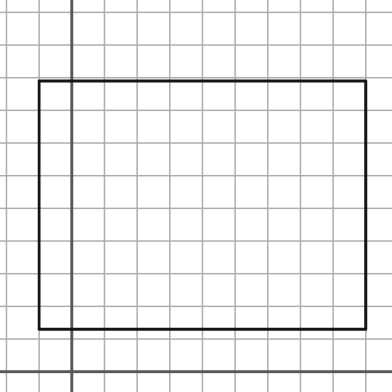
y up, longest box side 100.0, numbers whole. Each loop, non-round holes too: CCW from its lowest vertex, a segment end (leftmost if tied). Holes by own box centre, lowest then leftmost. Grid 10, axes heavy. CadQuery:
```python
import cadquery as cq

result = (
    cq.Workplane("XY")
    .moveTo(-10.0, 13.0)
    .lineTo(90.0, 13.0)
    .lineTo(90.0, 89.0)
    .lineTo(-10.0, 89.0)
    .close()
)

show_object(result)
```